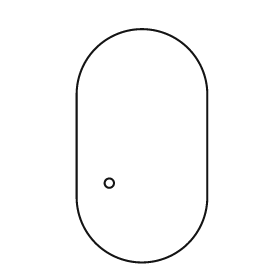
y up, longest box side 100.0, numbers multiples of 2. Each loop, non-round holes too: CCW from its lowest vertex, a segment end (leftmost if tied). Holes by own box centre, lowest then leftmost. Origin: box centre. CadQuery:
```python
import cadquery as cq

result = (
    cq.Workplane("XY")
    .moveTo(-28.0, -22.0)
    .threePointArc((0.0, -50.0), (28.0, -22.0))
    .lineTo(28.0, 22.0)
    .threePointArc((0.0, 50.0), (-28.0, 22.0))
    .close()
    .moveTo(-14.0, -16.0)
    .circle(2.0)
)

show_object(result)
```